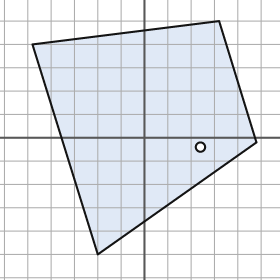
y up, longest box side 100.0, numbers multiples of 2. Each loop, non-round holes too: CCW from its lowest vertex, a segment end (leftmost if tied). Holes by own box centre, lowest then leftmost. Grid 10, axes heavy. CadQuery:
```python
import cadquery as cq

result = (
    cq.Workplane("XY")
    .moveTo(-20.0, -50.0)
    .lineTo(48.0, -2.0)
    .lineTo(32.0, 50.0)
    .lineTo(-48.0, 40.0)
    .close()
    .moveTo(24.0, -4.0)
    .circle(2.0)
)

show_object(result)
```